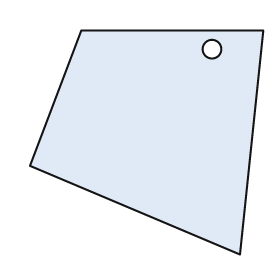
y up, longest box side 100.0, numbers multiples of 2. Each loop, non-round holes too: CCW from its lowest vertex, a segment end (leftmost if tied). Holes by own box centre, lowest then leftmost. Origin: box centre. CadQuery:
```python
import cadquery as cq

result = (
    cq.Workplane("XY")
    .moveTo(40.0, -48.0)
    .lineTo(50.0, 48.0)
    .lineTo(-28.0, 48.0)
    .lineTo(-50.0, -10.0)
    .close()
    .moveTo(28.0, 40.0)
    .circle(4.0)
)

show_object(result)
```